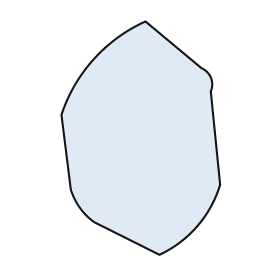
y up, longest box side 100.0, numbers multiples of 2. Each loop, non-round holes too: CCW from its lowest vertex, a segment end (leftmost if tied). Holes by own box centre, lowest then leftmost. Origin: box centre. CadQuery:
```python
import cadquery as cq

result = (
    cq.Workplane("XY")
    .moveTo(8.0, -50.0)
    .threePointArc((24.0, -38.0), (34.0, -20.0))
    .lineTo(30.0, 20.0)
    .threePointArc((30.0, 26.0), (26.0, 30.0))
    .lineTo(2.0, 50.0)
    .threePointArc((-20.0, 34.0), (-34.0, 10.0))
    .lineTo(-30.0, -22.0)
    .threePointArc((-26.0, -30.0), (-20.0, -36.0))
    .close()
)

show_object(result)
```